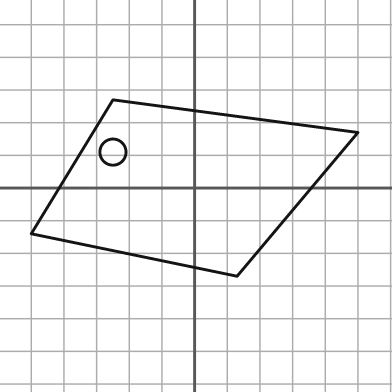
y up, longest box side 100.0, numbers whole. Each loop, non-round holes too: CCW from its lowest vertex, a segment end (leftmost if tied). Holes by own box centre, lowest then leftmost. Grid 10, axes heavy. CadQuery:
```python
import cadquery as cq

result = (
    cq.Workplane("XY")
    .moveTo(13.0, -27.0)
    .lineTo(50.0, 17.0)
    .lineTo(-25.0, 27.0)
    .lineTo(-50.0, -14.0)
    .close()
    .moveTo(-25.0, 11.0)
    .circle(4.0)
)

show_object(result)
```